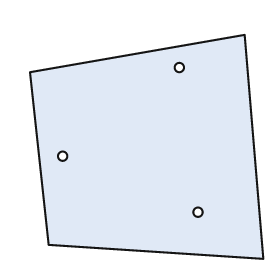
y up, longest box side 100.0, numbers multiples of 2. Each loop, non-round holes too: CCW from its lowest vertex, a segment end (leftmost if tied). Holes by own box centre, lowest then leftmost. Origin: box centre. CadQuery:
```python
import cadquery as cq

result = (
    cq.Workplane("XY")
    .moveTo(50.0, -48.0)
    .lineTo(42.0, 48.0)
    .lineTo(-50.0, 32.0)
    .lineTo(-42.0, -42.0)
    .close()
    .moveTo(22.0, -28.0)
    .circle(2.0)
    .moveTo(-36.0, -4.0)
    .circle(2.0)
    .moveTo(14.0, 34.0)
    .circle(2.0)
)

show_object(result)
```